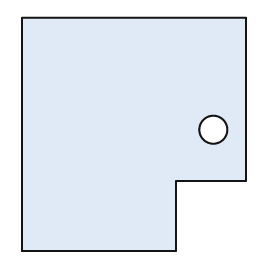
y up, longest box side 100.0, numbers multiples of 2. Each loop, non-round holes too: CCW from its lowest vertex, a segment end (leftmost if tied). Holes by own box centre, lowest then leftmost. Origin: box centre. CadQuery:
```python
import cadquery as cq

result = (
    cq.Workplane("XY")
    .moveTo(-48.0, -50.0)
    .lineTo(18.0, -50.0)
    .lineTo(18.0, -20.0)
    .lineTo(48.0, -20.0)
    .lineTo(48.0, 50.0)
    .lineTo(-48.0, 50.0)
    .close()
    .moveTo(34.0, 2.0)
    .circle(6.0)
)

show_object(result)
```